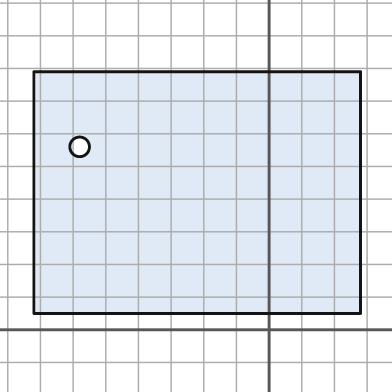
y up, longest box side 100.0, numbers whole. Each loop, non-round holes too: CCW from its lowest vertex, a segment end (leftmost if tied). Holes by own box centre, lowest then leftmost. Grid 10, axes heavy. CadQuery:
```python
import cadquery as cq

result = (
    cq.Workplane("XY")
    .moveTo(-72.0, 5.0)
    .lineTo(28.0, 5.0)
    .lineTo(28.0, 79.0)
    .lineTo(-72.0, 79.0)
    .close()
    .moveTo(-58.0, 56.0)
    .circle(3.0)
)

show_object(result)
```